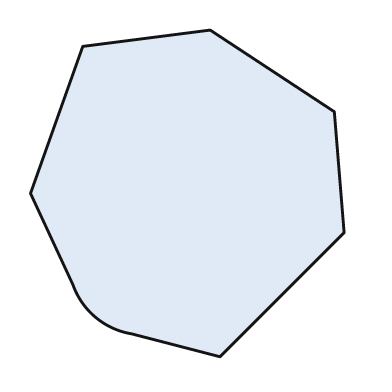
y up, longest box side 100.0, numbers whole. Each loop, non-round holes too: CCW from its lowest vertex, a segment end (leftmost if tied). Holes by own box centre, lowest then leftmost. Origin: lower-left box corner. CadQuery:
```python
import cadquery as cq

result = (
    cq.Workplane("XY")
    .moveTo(58.0, 0.0)
    .lineTo(96.0, 38.0)
    .lineTo(93.0, 75.0)
    .lineTo(55.0, 100.0)
    .lineTo(16.0, 95.0)
    .lineTo(0.0, 50.0)
    .lineTo(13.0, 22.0)
    .threePointArc((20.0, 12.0), (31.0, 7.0))
    .close()
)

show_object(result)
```